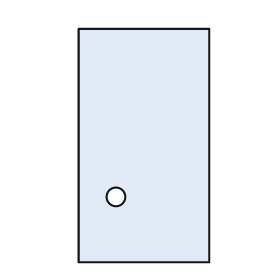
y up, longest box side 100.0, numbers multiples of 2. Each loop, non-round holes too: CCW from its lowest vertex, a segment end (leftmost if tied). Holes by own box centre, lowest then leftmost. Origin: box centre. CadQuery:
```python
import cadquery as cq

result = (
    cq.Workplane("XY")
    .moveTo(-28.0, -50.0)
    .lineTo(28.0, -50.0)
    .lineTo(28.0, 50.0)
    .lineTo(-28.0, 50.0)
    .close()
    .moveTo(-12.0, -22.0)
    .circle(4.0)
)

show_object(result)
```